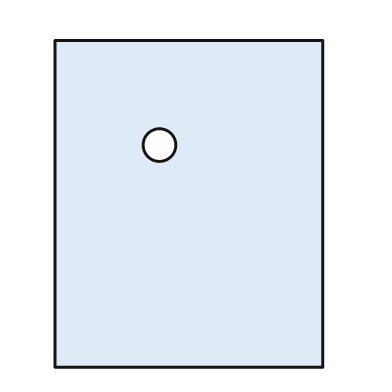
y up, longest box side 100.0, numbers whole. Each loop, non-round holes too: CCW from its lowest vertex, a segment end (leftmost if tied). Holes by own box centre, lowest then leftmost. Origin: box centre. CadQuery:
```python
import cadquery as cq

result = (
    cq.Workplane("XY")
    .moveTo(-41.0, -50.0)
    .lineTo(41.0, -50.0)
    .lineTo(41.0, 50.0)
    .lineTo(-41.0, 50.0)
    .close()
    .moveTo(-9.0, 18.0)
    .circle(5.0)
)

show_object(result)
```